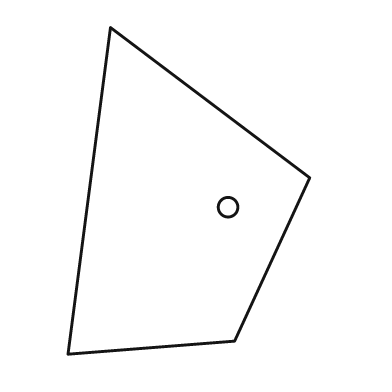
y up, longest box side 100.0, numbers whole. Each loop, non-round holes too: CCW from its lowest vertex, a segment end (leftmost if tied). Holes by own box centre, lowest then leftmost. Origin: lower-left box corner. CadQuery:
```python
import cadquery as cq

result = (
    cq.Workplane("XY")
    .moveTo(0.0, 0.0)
    .lineTo(51.0, 4.0)
    .lineTo(74.0, 54.0)
    .lineTo(13.0, 100.0)
    .close()
    .moveTo(49.0, 45.0)
    .circle(3.0)
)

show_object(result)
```